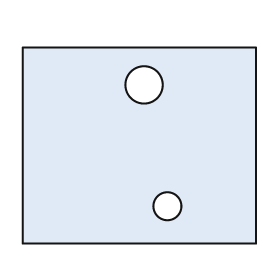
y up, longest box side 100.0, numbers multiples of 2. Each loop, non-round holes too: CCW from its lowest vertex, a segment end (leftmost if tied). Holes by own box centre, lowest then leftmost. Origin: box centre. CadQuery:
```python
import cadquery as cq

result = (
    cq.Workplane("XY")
    .moveTo(-50.0, -42.0)
    .lineTo(50.0, -42.0)
    .lineTo(50.0, 42.0)
    .lineTo(-50.0, 42.0)
    .close()
    .moveTo(12.0, -26.0)
    .circle(6.0)
    .moveTo(2.0, 26.0)
    .circle(8.0)
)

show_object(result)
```